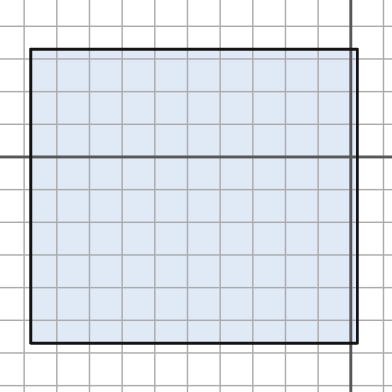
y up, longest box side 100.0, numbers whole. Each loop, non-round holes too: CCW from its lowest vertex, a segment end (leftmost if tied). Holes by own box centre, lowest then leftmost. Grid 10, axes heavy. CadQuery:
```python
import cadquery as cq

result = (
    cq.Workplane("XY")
    .moveTo(-98.0, -57.0)
    .lineTo(2.0, -57.0)
    .lineTo(2.0, 33.0)
    .lineTo(-98.0, 33.0)
    .close()
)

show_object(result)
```